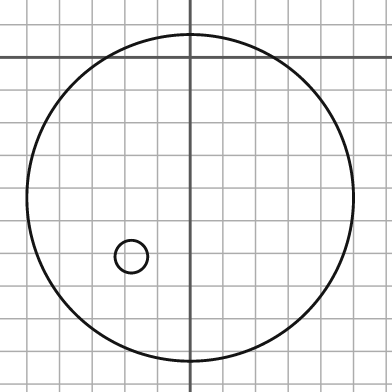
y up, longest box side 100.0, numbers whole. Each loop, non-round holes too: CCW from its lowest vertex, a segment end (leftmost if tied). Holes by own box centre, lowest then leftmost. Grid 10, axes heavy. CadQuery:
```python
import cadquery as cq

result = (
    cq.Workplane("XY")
    .moveTo(0.0, -43.0)
    .circle(50.0)
    .moveTo(-18.0, -61.0)
    .circle(5.0)
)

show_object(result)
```